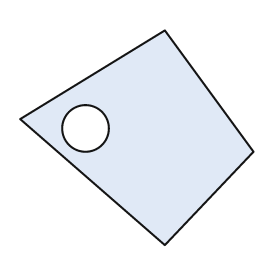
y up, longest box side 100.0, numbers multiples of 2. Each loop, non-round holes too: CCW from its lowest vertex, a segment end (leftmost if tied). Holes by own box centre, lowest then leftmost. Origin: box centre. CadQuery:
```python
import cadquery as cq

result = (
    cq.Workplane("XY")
    .moveTo(12.0, -46.0)
    .lineTo(50.0, -6.0)
    .lineTo(12.0, 46.0)
    .lineTo(-50.0, 8.0)
    .close()
    .moveTo(-22.0, 4.0)
    .circle(10.0)
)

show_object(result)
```